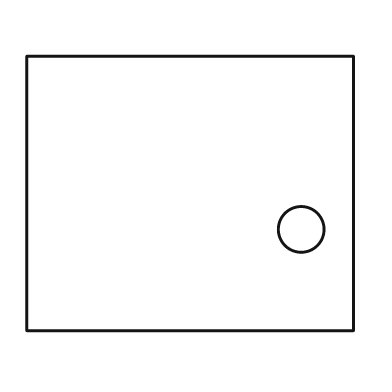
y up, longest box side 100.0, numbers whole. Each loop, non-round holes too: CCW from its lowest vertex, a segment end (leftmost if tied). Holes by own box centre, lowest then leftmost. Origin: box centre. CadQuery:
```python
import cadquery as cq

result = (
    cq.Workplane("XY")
    .moveTo(-50.0, -42.0)
    .lineTo(50.0, -42.0)
    .lineTo(50.0, 42.0)
    .lineTo(-50.0, 42.0)
    .close()
    .moveTo(34.0, -11.0)
    .circle(7.0)
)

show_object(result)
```